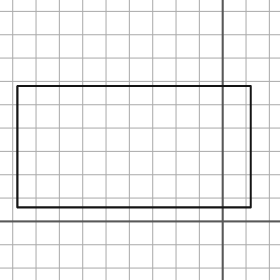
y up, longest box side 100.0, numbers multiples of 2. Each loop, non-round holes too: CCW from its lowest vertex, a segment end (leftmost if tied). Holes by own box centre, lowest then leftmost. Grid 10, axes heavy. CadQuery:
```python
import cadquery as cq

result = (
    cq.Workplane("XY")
    .moveTo(-88.0, 6.0)
    .lineTo(12.0, 6.0)
    .lineTo(12.0, 58.0)
    .lineTo(-88.0, 58.0)
    .close()
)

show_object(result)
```